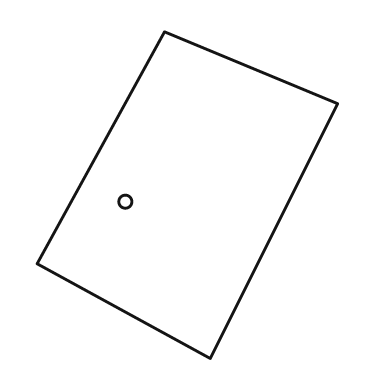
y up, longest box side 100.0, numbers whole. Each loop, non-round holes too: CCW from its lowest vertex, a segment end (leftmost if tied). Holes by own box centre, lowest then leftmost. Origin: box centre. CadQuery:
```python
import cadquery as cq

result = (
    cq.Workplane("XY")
    .moveTo(7.0, -50.0)
    .lineTo(46.0, 28.0)
    .lineTo(-7.0, 50.0)
    .lineTo(-46.0, -21.0)
    .close()
    .moveTo(-19.0, -2.0)
    .circle(2.0)
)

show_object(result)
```